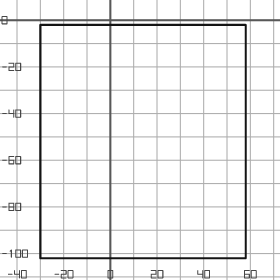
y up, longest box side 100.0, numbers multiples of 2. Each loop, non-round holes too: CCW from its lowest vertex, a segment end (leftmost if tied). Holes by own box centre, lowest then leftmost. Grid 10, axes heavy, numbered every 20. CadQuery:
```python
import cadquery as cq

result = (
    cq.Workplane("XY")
    .moveTo(-30.0, -102.0)
    .lineTo(58.0, -102.0)
    .lineTo(58.0, -2.0)
    .lineTo(-30.0, -2.0)
    .close()
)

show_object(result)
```